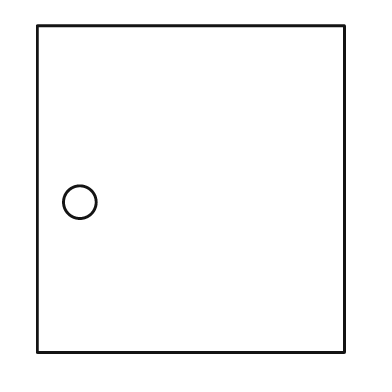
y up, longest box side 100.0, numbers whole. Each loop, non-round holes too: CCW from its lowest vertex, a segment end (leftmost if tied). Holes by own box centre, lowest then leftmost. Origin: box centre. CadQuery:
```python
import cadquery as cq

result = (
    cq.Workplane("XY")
    .moveTo(-47.0, -50.0)
    .lineTo(47.0, -50.0)
    .lineTo(47.0, 50.0)
    .lineTo(-47.0, 50.0)
    .close()
    .moveTo(-34.0, -4.0)
    .circle(5.0)
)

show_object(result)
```